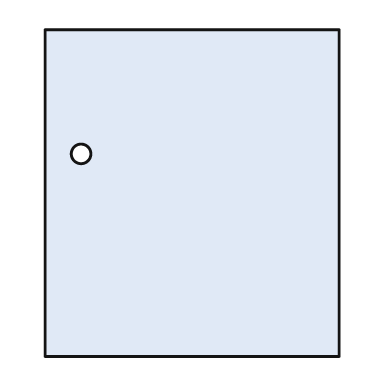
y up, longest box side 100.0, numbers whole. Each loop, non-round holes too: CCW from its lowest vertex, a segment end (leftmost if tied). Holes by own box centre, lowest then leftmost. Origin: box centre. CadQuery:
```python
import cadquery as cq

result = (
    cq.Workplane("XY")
    .moveTo(-45.0, -50.0)
    .lineTo(45.0, -50.0)
    .lineTo(45.0, 50.0)
    .lineTo(-45.0, 50.0)
    .close()
    .moveTo(-34.0, 12.0)
    .circle(3.0)
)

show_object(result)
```